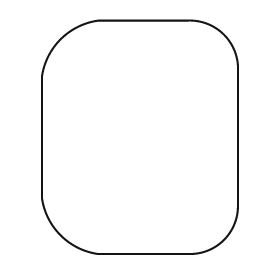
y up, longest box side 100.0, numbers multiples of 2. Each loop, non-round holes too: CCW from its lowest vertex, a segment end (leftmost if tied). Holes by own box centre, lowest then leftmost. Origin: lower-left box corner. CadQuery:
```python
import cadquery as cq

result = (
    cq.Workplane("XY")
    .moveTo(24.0, 0.0)
    .lineTo(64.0, 0.0)
    .threePointArc((78.0, 6.0), (84.0, 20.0))
    .lineTo(84.0, 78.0)
    .threePointArc((78.0, 94.0), (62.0, 100.0))
    .lineTo(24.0, 100.0)
    .threePointArc((8.0, 92.0), (0.0, 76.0))
    .lineTo(0.0, 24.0)
    .threePointArc((8.0, 8.0), (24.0, 0.0))
    .close()
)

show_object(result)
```